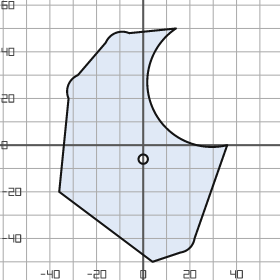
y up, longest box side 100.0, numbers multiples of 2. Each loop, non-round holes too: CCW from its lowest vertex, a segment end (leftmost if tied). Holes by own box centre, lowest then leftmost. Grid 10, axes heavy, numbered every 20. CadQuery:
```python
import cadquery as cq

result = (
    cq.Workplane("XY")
    .moveTo(4.0, -50.0)
    .lineTo(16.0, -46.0)
    .threePointArc((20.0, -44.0), (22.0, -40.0))
    .lineTo(36.0, 0.0)
    .threePointArc((4.0, 16.0), (14.0, 50.0))
    .lineTo(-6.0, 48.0)
    .threePointArc((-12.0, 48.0), (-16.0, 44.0))
    .lineTo(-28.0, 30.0)
    .threePointArc((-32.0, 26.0), (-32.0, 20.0))
    .lineTo(-36.0, -20.0)
    .close()
    .moveTo(0.0, -6.0)
    .circle(2.0)
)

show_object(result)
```